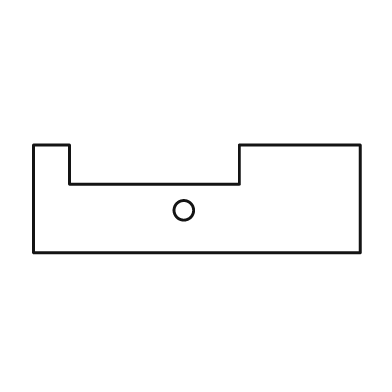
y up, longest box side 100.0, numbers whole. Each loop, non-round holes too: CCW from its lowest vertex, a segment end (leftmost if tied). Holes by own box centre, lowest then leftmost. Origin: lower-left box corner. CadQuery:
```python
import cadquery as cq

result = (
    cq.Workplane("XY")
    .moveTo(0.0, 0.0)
    .lineTo(100.0, 0.0)
    .lineTo(100.0, 33.0)
    .lineTo(63.0, 33.0)
    .lineTo(63.0, 21.0)
    .lineTo(11.0, 21.0)
    .lineTo(11.0, 33.0)
    .lineTo(0.0, 33.0)
    .close()
    .moveTo(46.0, 13.0)
    .circle(3.0)
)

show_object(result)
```